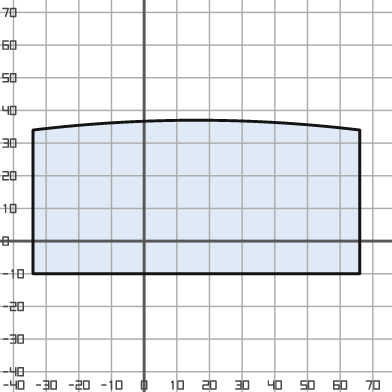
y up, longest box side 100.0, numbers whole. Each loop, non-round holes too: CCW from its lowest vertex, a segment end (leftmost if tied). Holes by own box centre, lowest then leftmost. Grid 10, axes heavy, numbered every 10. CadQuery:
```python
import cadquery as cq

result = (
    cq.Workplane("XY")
    .moveTo(-34.0, -10.0)
    .lineTo(66.0, -10.0)
    .lineTo(66.0, 34.0)
    .threePointArc((16.0, 37.0), (-34.0, 34.0))
    .close()
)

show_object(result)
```